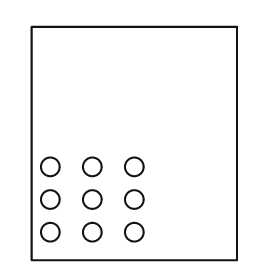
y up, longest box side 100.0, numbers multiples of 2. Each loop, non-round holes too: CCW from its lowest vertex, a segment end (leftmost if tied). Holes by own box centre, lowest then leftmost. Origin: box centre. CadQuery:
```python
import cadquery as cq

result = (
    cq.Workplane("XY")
    .moveTo(-44.0, -50.0)
    .lineTo(44.0, -50.0)
    .lineTo(44.0, 50.0)
    .lineTo(-44.0, 50.0)
    .close()
    .moveTo(-36.0, -38.0)
    .circle(4.0)
    .moveTo(-18.0, -38.0)
    .circle(4.0)
    .moveTo(0.0, -38.0)
    .circle(4.0)
    .moveTo(-36.0, -24.0)
    .circle(4.0)
    .moveTo(-18.0, -24.0)
    .circle(4.0)
    .moveTo(0.0, -24.0)
    .circle(4.0)
    .moveTo(-36.0, -10.0)
    .circle(4.0)
    .moveTo(-18.0, -10.0)
    .circle(4.0)
    .moveTo(0.0, -10.0)
    .circle(4.0)
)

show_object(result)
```